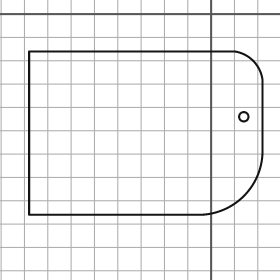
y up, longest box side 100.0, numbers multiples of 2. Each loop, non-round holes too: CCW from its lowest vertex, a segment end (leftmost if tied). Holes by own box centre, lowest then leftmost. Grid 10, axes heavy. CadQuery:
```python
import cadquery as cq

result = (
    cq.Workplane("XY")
    .moveTo(-78.0, -86.0)
    .lineTo(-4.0, -86.0)
    .threePointArc((14.0, -78.0), (22.0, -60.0))
    .lineTo(22.0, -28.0)
    .threePointArc((18.0, -20.0), (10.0, -16.0))
    .lineTo(-78.0, -16.0)
    .close()
    .moveTo(14.0, -44.0)
    .circle(2.0)
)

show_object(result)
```